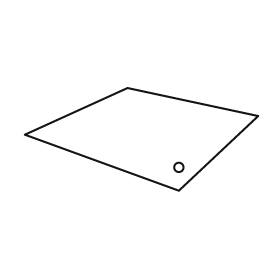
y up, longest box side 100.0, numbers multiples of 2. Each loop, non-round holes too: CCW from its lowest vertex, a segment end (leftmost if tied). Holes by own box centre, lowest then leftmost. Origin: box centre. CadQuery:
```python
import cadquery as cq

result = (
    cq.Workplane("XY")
    .moveTo(16.0, -22.0)
    .lineTo(50.0, 10.0)
    .lineTo(-6.0, 22.0)
    .lineTo(-50.0, 2.0)
    .close()
    .moveTo(16.0, -12.0)
    .circle(2.0)
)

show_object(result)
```